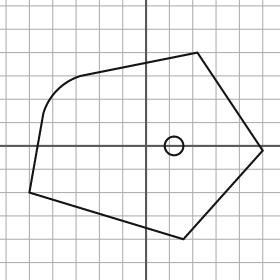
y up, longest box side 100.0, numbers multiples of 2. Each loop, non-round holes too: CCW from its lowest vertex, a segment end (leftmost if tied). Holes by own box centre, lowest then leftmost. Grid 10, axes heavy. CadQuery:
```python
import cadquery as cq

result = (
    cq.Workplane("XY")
    .moveTo(16.0, -40.0)
    .lineTo(50.0, -2.0)
    .lineTo(22.0, 40.0)
    .lineTo(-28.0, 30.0)
    .threePointArc((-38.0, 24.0), (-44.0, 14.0))
    .lineTo(-50.0, -20.0)
    .close()
    .moveTo(12.0, 0.0)
    .circle(4.0)
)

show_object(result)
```